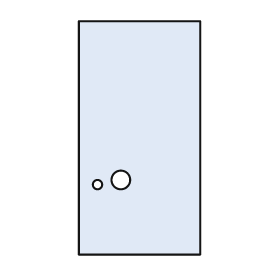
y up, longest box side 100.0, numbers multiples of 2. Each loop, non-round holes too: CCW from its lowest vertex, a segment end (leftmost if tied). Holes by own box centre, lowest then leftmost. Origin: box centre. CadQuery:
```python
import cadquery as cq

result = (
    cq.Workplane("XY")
    .moveTo(-26.0, -50.0)
    .lineTo(26.0, -50.0)
    .lineTo(26.0, 50.0)
    .lineTo(-26.0, 50.0)
    .close()
    .moveTo(-18.0, -20.0)
    .circle(2.0)
    .moveTo(-8.0, -18.0)
    .circle(4.0)
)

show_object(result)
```